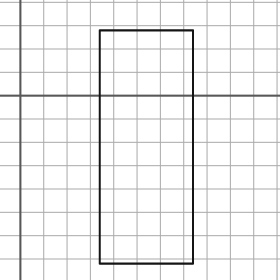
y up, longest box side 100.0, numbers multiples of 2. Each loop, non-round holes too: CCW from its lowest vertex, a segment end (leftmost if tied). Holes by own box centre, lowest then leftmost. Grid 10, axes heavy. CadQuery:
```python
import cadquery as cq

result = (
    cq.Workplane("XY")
    .moveTo(34.0, -72.0)
    .lineTo(74.0, -72.0)
    .lineTo(74.0, 28.0)
    .lineTo(34.0, 28.0)
    .close()
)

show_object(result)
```